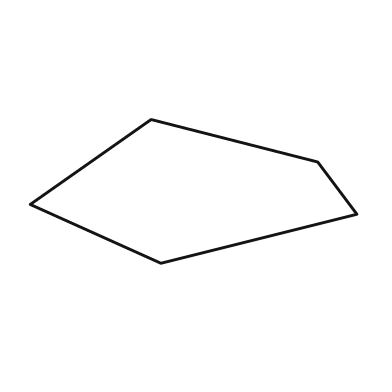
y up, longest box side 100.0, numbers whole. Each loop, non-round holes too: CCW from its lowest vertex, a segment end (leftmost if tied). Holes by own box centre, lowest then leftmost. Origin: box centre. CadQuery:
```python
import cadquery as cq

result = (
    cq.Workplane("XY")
    .moveTo(-10.0, -22.0)
    .lineTo(50.0, -7.0)
    .lineTo(38.0, 9.0)
    .lineTo(-13.0, 22.0)
    .lineTo(-50.0, -4.0)
    .close()
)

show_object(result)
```